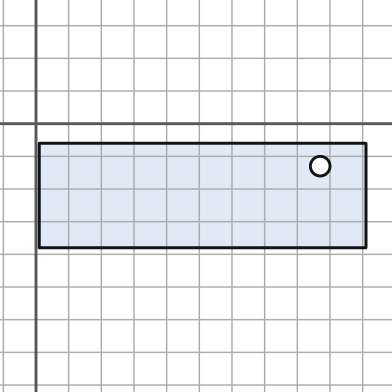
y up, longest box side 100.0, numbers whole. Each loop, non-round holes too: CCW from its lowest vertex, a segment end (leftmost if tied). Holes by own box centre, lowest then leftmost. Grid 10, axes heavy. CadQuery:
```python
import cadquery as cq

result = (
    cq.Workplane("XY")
    .moveTo(1.0, -38.0)
    .lineTo(101.0, -38.0)
    .lineTo(101.0, -6.0)
    .lineTo(1.0, -6.0)
    .close()
    .moveTo(87.0, -13.0)
    .circle(3.0)
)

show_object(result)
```